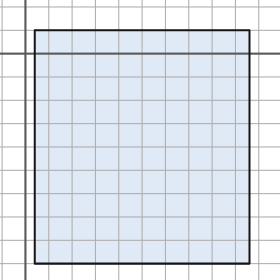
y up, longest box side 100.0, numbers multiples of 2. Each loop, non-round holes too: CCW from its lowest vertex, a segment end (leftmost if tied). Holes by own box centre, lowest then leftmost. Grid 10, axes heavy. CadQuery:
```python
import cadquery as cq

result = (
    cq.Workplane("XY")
    .moveTo(4.0, -90.0)
    .lineTo(96.0, -90.0)
    .lineTo(96.0, 10.0)
    .lineTo(4.0, 10.0)
    .close()
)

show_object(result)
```